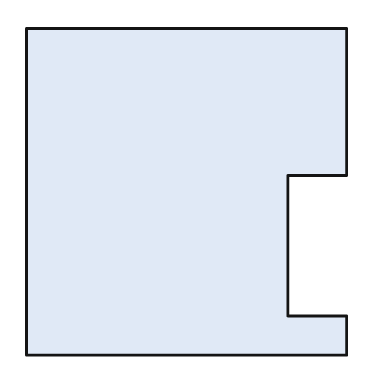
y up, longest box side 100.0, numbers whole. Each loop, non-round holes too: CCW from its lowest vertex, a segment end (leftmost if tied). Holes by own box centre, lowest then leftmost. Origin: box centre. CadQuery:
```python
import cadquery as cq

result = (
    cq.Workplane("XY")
    .moveTo(-49.0, -50.0)
    .lineTo(49.0, -50.0)
    .lineTo(49.0, -38.0)
    .lineTo(31.0, -38.0)
    .lineTo(31.0, 5.0)
    .lineTo(49.0, 5.0)
    .lineTo(49.0, 50.0)
    .lineTo(-49.0, 50.0)
    .close()
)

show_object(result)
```